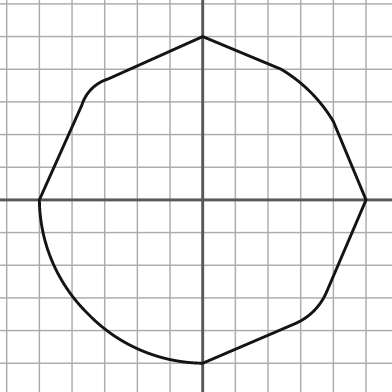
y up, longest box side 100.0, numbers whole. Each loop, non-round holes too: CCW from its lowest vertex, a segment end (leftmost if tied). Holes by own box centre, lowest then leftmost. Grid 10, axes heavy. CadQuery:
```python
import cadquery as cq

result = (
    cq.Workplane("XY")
    .moveTo(0.0, -50.0)
    .lineTo(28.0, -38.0)
    .threePointArc((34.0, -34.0), (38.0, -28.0))
    .lineTo(50.0, 0.0)
    .lineTo(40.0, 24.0)
    .threePointArc((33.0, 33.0), (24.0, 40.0))
    .lineTo(0.0, 50.0)
    .lineTo(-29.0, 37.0)
    .threePointArc((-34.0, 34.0), (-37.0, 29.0))
    .lineTo(-50.0, 0.0)
    .threePointArc((-46.0, -19.0), (-35.0, -35.0))
    .threePointArc((-19.0, -46.0), (0.0, -50.0))
    .close()
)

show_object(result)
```